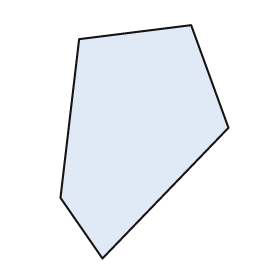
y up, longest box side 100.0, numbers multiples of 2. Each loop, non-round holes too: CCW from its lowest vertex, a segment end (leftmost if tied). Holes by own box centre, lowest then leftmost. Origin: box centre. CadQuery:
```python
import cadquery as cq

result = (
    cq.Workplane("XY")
    .moveTo(-18.0, -50.0)
    .lineTo(36.0, 6.0)
    .lineTo(20.0, 50.0)
    .lineTo(-28.0, 44.0)
    .lineTo(-36.0, -24.0)
    .close()
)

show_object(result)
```